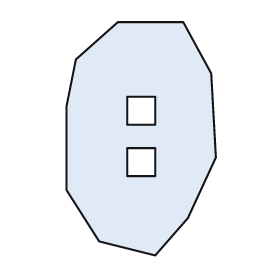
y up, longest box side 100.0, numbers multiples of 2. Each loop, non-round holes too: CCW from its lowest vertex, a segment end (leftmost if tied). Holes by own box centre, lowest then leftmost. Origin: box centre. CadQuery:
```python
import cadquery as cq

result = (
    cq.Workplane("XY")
    .moveTo(6.0, -50.0)
    .lineTo(20.0, -34.0)
    .lineTo(32.0, -8.0)
    .lineTo(30.0, 28.0)
    .lineTo(18.0, 50.0)
    .lineTo(-10.0, 50.0)
    .lineTo(-28.0, 34.0)
    .lineTo(-32.0, 14.0)
    .lineTo(-32.0, -22.0)
    .lineTo(-18.0, -44.0)
    .close()
    .moveTo(-6.0, -16.0)
    .lineTo(6.0, -16.0)
    .lineTo(6.0, -4.0)
    .lineTo(-6.0, -4.0)
    .close()
    .moveTo(-6.0, 6.0)
    .lineTo(6.0, 6.0)
    .lineTo(6.0, 18.0)
    .lineTo(-6.0, 18.0)
    .close()
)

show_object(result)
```